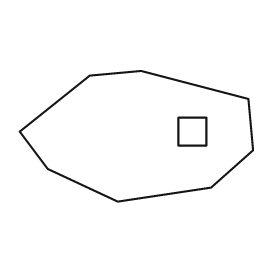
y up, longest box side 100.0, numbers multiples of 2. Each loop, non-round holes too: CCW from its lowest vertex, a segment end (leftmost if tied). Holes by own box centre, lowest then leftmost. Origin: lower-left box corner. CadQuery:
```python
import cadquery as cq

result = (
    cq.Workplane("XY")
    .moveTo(42.0, 0.0)
    .lineTo(82.0, 6.0)
    .lineTo(100.0, 22.0)
    .lineTo(98.0, 44.0)
    .lineTo(52.0, 56.0)
    .lineTo(30.0, 54.0)
    .lineTo(0.0, 30.0)
    .lineTo(12.0, 14.0)
    .close()
    .moveTo(68.0, 24.0)
    .lineTo(80.0, 24.0)
    .lineTo(80.0, 36.0)
    .lineTo(68.0, 36.0)
    .close()
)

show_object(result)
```